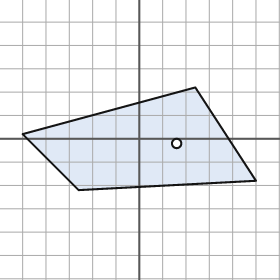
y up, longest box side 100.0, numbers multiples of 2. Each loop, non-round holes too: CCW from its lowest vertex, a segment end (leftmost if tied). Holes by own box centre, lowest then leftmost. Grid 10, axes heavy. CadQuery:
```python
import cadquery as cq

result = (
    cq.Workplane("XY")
    .moveTo(-26.0, -22.0)
    .lineTo(50.0, -18.0)
    .lineTo(24.0, 22.0)
    .lineTo(-50.0, 2.0)
    .close()
    .moveTo(16.0, -2.0)
    .circle(2.0)
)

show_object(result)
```